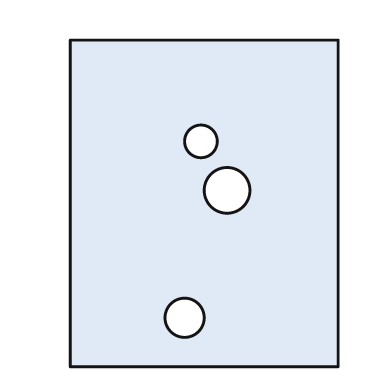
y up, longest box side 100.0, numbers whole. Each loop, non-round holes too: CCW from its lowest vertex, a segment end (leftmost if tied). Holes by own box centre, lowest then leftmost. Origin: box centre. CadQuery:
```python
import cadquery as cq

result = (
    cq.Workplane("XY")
    .moveTo(-41.0, -50.0)
    .lineTo(41.0, -50.0)
    .lineTo(41.0, 50.0)
    .lineTo(-41.0, 50.0)
    .close()
    .moveTo(-6.0, -35.0)
    .circle(6.0)
    .moveTo(7.0, 4.0)
    .circle(7.0)
    .moveTo(-1.0, 19.0)
    .circle(5.0)
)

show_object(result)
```